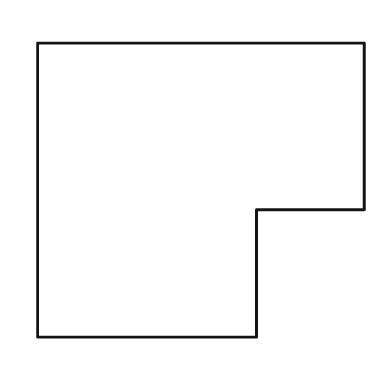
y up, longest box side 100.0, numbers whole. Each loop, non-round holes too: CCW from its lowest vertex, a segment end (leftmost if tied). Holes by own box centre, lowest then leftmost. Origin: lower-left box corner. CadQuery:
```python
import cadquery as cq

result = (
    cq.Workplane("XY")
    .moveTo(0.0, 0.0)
    .lineTo(67.0, 0.0)
    .lineTo(67.0, 39.0)
    .lineTo(100.0, 39.0)
    .lineTo(100.0, 90.0)
    .lineTo(0.0, 90.0)
    .close()
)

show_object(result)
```